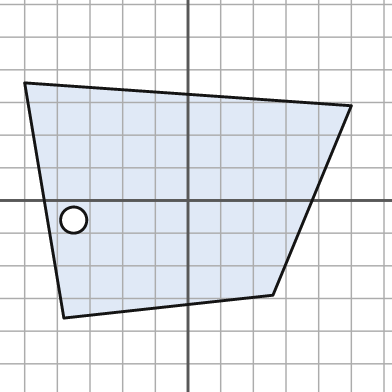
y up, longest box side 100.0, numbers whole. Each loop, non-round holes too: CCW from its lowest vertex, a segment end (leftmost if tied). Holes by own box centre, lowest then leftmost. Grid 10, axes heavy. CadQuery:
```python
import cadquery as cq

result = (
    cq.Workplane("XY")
    .moveTo(-38.0, -36.0)
    .lineTo(26.0, -29.0)
    .lineTo(50.0, 29.0)
    .lineTo(-50.0, 36.0)
    .close()
    .moveTo(-35.0, -6.0)
    .circle(4.0)
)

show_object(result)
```